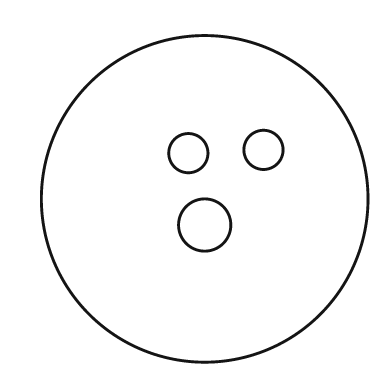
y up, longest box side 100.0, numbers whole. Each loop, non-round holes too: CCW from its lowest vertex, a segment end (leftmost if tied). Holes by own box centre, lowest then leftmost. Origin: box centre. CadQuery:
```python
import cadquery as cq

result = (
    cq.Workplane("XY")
    .moveTo(0.0, 0.0)
    .circle(50.0)
    .moveTo(0.0, -8.0)
    .circle(8.0)
    .moveTo(-5.0, 14.0)
    .circle(6.0)
    .moveTo(18.0, 15.0)
    .circle(6.0)
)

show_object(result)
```